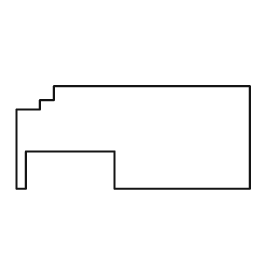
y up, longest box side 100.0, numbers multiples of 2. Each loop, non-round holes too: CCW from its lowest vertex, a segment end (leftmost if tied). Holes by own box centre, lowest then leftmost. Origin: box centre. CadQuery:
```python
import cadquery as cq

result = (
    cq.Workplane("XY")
    .moveTo(-50.0, -22.0)
    .lineTo(-46.0, -22.0)
    .lineTo(-46.0, -6.0)
    .lineTo(-8.0, -6.0)
    .lineTo(-8.0, -22.0)
    .lineTo(50.0, -22.0)
    .lineTo(50.0, 22.0)
    .lineTo(-34.0, 22.0)
    .lineTo(-34.0, 16.0)
    .lineTo(-40.0, 16.0)
    .lineTo(-40.0, 12.0)
    .lineTo(-50.0, 12.0)
    .close()
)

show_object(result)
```